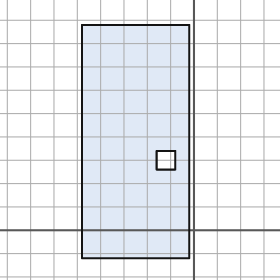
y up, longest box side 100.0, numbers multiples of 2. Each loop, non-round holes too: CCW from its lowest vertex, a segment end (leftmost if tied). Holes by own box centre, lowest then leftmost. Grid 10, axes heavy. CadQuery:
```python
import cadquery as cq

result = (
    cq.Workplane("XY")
    .moveTo(-48.0, -12.0)
    .lineTo(-2.0, -12.0)
    .lineTo(-2.0, 88.0)
    .lineTo(-48.0, 88.0)
    .close()
    .moveTo(-16.0, 26.0)
    .lineTo(-8.0, 26.0)
    .lineTo(-8.0, 34.0)
    .lineTo(-16.0, 34.0)
    .close()
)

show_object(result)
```